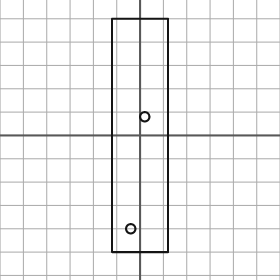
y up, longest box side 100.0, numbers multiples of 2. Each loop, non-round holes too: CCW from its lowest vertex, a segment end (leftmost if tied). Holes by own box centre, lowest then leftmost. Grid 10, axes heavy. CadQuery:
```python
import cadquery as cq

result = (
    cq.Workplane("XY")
    .moveTo(-12.0, -50.0)
    .lineTo(12.0, -50.0)
    .lineTo(12.0, 50.0)
    .lineTo(-12.0, 50.0)
    .close()
    .moveTo(-4.0, -40.0)
    .circle(2.0)
    .moveTo(2.0, 8.0)
    .circle(2.0)
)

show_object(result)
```